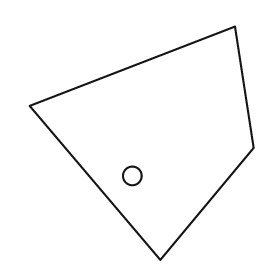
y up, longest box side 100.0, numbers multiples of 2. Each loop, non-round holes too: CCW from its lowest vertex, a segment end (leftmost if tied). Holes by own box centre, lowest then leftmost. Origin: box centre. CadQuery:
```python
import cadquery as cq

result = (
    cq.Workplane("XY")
    .moveTo(8.0, -50.0)
    .lineTo(48.0, -2.0)
    .lineTo(40.0, 50.0)
    .lineTo(-48.0, 16.0)
    .close()
    .moveTo(-4.0, -14.0)
    .circle(4.0)
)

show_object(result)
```